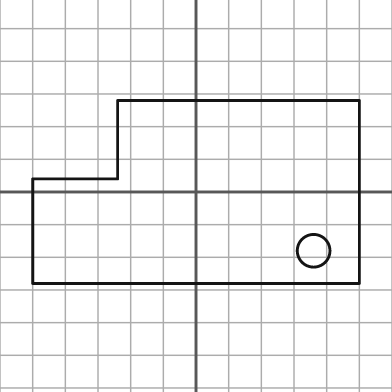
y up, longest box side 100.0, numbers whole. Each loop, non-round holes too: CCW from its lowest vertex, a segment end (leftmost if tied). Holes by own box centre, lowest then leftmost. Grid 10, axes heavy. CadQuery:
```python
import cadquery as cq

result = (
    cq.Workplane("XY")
    .moveTo(-50.0, -28.0)
    .lineTo(50.0, -28.0)
    .lineTo(50.0, 28.0)
    .lineTo(-24.0, 28.0)
    .lineTo(-24.0, 4.0)
    .lineTo(-50.0, 4.0)
    .close()
    .moveTo(36.0, -18.0)
    .circle(5.0)
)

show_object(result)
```